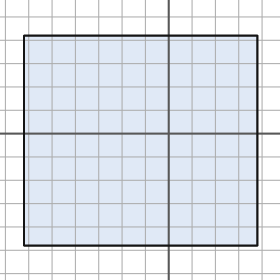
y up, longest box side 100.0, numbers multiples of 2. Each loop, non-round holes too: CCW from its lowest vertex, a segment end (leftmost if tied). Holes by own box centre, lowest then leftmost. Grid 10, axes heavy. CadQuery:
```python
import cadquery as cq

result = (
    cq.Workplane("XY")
    .moveTo(-62.0, -48.0)
    .lineTo(38.0, -48.0)
    .lineTo(38.0, 42.0)
    .lineTo(-62.0, 42.0)
    .close()
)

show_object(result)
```